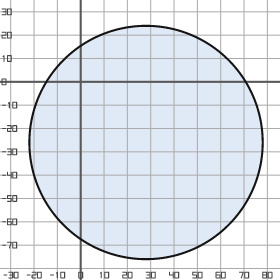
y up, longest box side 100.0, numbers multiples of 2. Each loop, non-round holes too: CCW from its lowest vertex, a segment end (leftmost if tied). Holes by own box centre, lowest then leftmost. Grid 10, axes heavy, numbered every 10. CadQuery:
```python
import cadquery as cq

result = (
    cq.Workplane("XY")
    .moveTo(28.0, -26.0)
    .circle(50.0)
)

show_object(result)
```